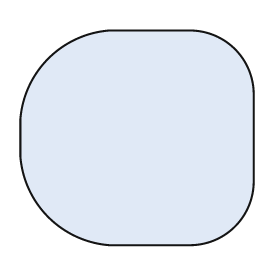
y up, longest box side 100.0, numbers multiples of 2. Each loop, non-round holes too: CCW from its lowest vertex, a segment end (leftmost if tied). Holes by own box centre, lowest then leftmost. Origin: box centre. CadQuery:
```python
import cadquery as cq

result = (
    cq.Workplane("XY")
    .moveTo(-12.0, -46.0)
    .lineTo(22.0, -46.0)
    .threePointArc((42.0, -38.0), (50.0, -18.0))
    .lineTo(50.0, 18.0)
    .threePointArc((42.0, 38.0), (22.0, 46.0))
    .lineTo(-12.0, 46.0)
    .threePointArc((-38.0, 34.0), (-50.0, 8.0))
    .lineTo(-50.0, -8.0)
    .threePointArc((-38.0, -34.0), (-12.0, -46.0))
    .close()
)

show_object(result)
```